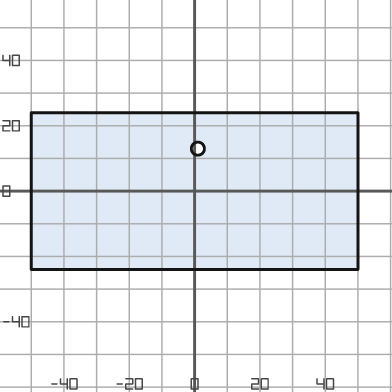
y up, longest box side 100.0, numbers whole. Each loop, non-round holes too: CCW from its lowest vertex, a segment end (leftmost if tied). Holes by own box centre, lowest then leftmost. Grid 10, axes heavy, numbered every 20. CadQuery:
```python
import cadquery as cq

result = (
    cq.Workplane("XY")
    .moveTo(-50.0, -24.0)
    .lineTo(50.0, -24.0)
    .lineTo(50.0, 24.0)
    .lineTo(-50.0, 24.0)
    .close()
    .moveTo(1.0, 13.0)
    .circle(2.0)
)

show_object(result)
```